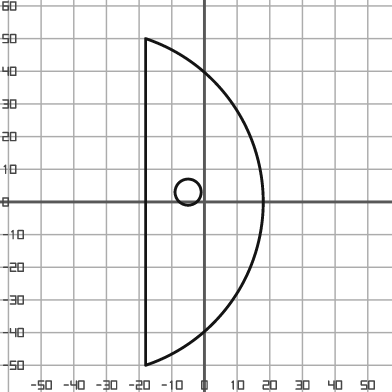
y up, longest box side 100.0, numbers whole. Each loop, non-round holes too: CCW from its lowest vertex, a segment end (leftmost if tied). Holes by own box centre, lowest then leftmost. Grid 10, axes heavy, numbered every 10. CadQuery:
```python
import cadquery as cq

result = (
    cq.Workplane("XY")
    .moveTo(-18.0, -50.0)
    .threePointArc((18.0, 0.0), (-18.0, 50.0))
    .close()
    .moveTo(-5.0, 3.0)
    .circle(4.0)
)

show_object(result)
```